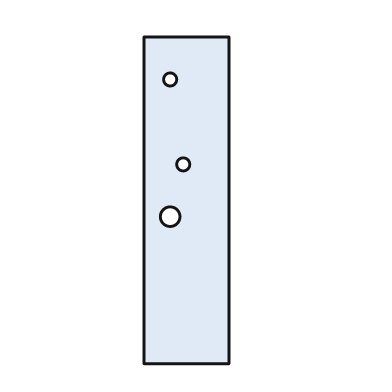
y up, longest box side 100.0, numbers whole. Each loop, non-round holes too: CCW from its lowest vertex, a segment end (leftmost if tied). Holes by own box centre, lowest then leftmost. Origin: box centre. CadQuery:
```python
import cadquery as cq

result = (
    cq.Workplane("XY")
    .moveTo(-13.0, -50.0)
    .lineTo(13.0, -50.0)
    .lineTo(13.0, 50.0)
    .lineTo(-13.0, 50.0)
    .close()
    .moveTo(-5.0, -5.0)
    .circle(3.0)
    .moveTo(-1.0, 11.0)
    .circle(2.0)
    .moveTo(-5.0, 37.0)
    .circle(2.0)
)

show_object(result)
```